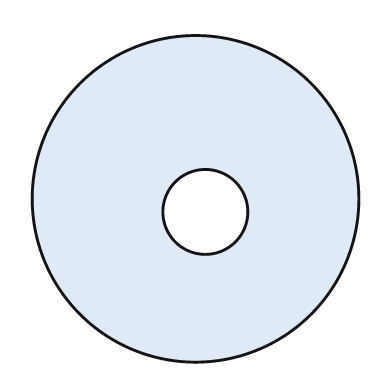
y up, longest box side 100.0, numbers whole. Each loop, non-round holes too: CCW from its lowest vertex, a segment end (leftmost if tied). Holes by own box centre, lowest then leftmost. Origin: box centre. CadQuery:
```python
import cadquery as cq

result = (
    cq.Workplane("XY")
    .moveTo(0.0, 0.0)
    .circle(50.0)
    .moveTo(3.0, -4.0)
    .circle(13.0)
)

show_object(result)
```